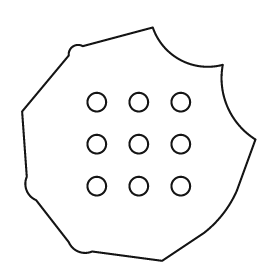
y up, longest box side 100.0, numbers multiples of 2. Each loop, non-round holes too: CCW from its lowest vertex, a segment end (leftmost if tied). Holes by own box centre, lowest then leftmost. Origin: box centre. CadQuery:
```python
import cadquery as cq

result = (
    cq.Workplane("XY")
    .moveTo(10.0, -50.0)
    .lineTo(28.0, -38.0)
    .threePointArc((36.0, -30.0), (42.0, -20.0))
    .lineTo(50.0, 2.0)
    .threePointArc((38.0, 16.0), (36.0, 34.0))
    .threePointArc((18.0, 36.0), (6.0, 50.0))
    .lineTo(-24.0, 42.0)
    .threePointArc((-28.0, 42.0), (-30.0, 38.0))
    .lineTo(-50.0, 14.0)
    .lineTo(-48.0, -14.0)
    .threePointArc((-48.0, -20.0), (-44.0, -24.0))
    .lineTo(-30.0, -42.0)
    .threePointArc((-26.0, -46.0), (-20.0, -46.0))
    .close()
    .moveTo(-18.0, -18.0)
    .circle(4.0)
    .moveTo(0.0, -18.0)
    .circle(4.0)
    .moveTo(18.0, -18.0)
    .circle(4.0)
    .moveTo(-18.0, 0.0)
    .circle(4.0)
    .moveTo(0.0, 0.0)
    .circle(4.0)
    .moveTo(18.0, 0.0)
    .circle(4.0)
    .moveTo(-18.0, 18.0)
    .circle(4.0)
    .moveTo(0.0, 18.0)
    .circle(4.0)
    .moveTo(18.0, 18.0)
    .circle(4.0)
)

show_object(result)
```